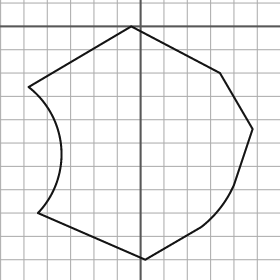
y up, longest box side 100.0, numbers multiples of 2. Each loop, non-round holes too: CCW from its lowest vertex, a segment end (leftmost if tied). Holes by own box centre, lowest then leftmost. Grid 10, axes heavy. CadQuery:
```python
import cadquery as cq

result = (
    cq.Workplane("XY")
    .moveTo(2.0, -100.0)
    .lineTo(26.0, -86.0)
    .threePointArc((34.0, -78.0), (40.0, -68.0))
    .lineTo(48.0, -44.0)
    .lineTo(34.0, -20.0)
    .lineTo(-4.0, 0.0)
    .lineTo(-48.0, -26.0)
    .threePointArc((-34.0, -52.0), (-44.0, -80.0))
    .close()
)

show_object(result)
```